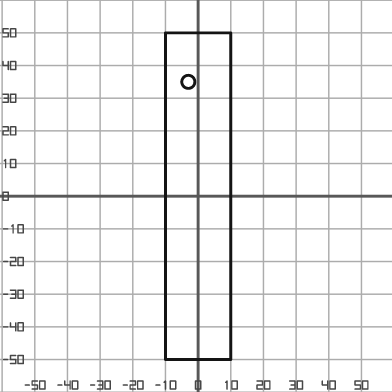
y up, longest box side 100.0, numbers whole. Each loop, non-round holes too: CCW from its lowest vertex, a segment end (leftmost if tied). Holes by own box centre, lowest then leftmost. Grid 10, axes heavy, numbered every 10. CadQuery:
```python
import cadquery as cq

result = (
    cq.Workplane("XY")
    .moveTo(-10.0, -50.0)
    .lineTo(10.0, -50.0)
    .lineTo(10.0, 50.0)
    .lineTo(-10.0, 50.0)
    .close()
    .moveTo(-3.0, 35.0)
    .circle(2.0)
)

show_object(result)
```